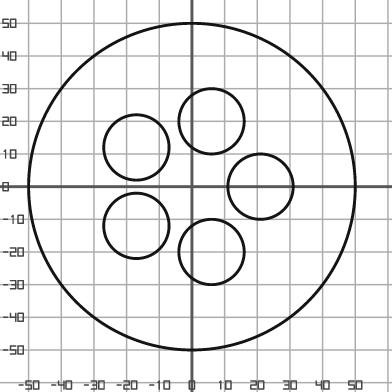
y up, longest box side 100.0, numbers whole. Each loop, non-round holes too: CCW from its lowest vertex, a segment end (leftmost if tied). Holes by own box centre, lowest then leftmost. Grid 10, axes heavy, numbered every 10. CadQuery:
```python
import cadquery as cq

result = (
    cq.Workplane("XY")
    .moveTo(0.0, 0.0)
    .circle(50.0)
    .moveTo(6.0, -20.0)
    .circle(10.0)
    .moveTo(-17.0, -12.0)
    .circle(10.0)
    .moveTo(21.0, 0.0)
    .circle(10.0)
    .moveTo(-17.0, 12.0)
    .circle(10.0)
    .moveTo(6.0, 20.0)
    .circle(10.0)
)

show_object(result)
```